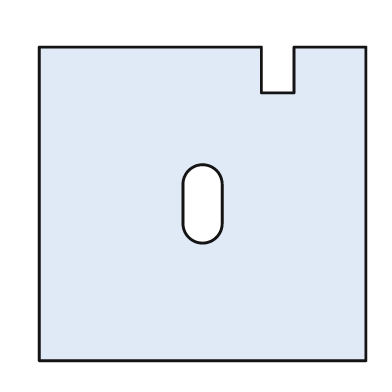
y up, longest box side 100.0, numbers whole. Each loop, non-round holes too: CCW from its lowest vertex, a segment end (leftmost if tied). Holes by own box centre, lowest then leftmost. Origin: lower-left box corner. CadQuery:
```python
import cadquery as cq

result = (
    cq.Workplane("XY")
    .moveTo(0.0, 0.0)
    .lineTo(100.0, 0.0)
    .lineTo(100.0, 96.0)
    .lineTo(78.0, 96.0)
    .lineTo(78.0, 82.0)
    .lineTo(68.0, 82.0)
    .lineTo(68.0, 96.0)
    .lineTo(0.0, 96.0)
    .close()
    .moveTo(44.0, 42.0)
    .threePointArc((50.0, 36.0), (56.0, 42.0))
    .lineTo(56.0, 54.0)
    .threePointArc((50.0, 60.0), (44.0, 54.0))
    .close()
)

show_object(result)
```